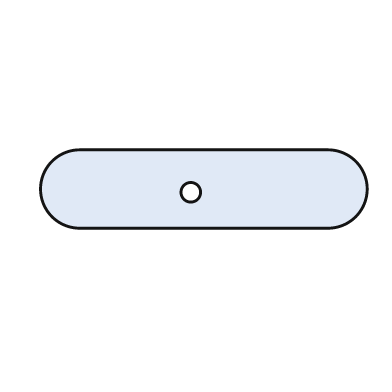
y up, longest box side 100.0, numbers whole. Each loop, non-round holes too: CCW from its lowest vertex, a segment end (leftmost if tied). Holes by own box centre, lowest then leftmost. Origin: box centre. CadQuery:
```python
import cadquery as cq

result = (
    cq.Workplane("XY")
    .moveTo(-38.0, -12.0)
    .lineTo(38.0, -12.0)
    .threePointArc((50.0, 0.0), (38.0, 12.0))
    .lineTo(-38.0, 12.0)
    .threePointArc((-50.0, 0.0), (-38.0, -12.0))
    .close()
    .moveTo(-4.0, -1.0)
    .circle(3.0)
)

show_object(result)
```